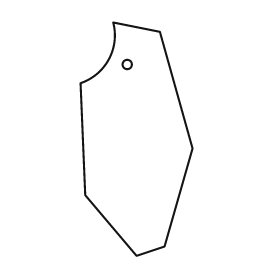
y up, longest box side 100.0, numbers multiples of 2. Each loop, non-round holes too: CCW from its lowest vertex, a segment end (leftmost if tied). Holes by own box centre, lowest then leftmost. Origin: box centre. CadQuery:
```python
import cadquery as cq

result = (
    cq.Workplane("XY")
    .moveTo(0.0, -50.0)
    .lineTo(12.0, -46.0)
    .lineTo(24.0, -4.0)
    .lineTo(10.0, 46.0)
    .lineTo(-10.0, 50.0)
    .threePointArc((-12.0, 34.0), (-24.0, 24.0))
    .lineTo(-22.0, -24.0)
    .close()
    .moveTo(-4.0, 32.0)
    .circle(2.0)
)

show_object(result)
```